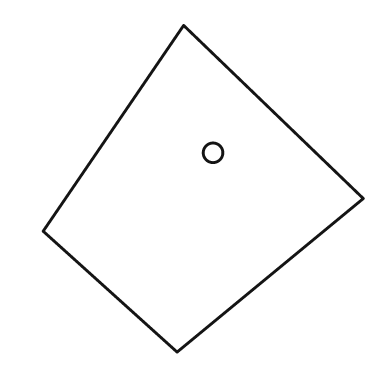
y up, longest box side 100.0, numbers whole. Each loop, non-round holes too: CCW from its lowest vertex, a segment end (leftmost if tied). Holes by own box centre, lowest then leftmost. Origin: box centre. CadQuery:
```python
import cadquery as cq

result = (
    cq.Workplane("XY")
    .moveTo(-8.0, -50.0)
    .lineTo(49.0, -3.0)
    .lineTo(-6.0, 50.0)
    .lineTo(-49.0, -13.0)
    .close()
    .moveTo(3.0, 11.0)
    .circle(3.0)
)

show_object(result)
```